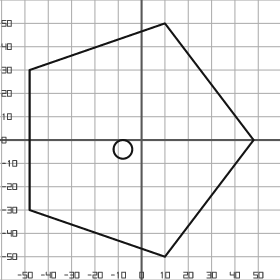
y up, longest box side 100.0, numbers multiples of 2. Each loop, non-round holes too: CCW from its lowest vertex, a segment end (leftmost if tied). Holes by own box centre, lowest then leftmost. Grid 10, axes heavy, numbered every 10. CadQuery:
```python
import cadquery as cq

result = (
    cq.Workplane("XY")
    .moveTo(10.0, -50.0)
    .lineTo(48.0, 0.0)
    .lineTo(10.0, 50.0)
    .lineTo(-48.0, 30.0)
    .lineTo(-48.0, -30.0)
    .close()
    .moveTo(-8.0, -4.0)
    .circle(4.0)
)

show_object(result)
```